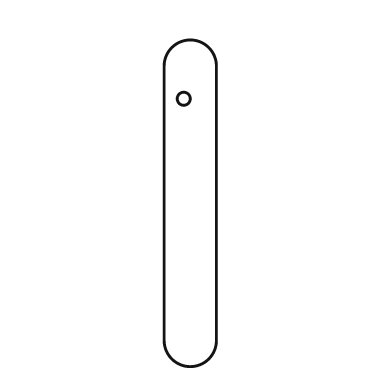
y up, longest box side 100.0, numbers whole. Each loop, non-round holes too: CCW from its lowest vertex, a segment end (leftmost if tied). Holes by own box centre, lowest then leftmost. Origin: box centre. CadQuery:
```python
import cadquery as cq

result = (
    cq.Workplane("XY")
    .moveTo(-8.0, -42.0)
    .threePointArc((0.0, -50.0), (8.0, -42.0))
    .lineTo(8.0, 42.0)
    .threePointArc((0.0, 50.0), (-8.0, 42.0))
    .close()
    .moveTo(-2.0, 32.0)
    .circle(2.0)
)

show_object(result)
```